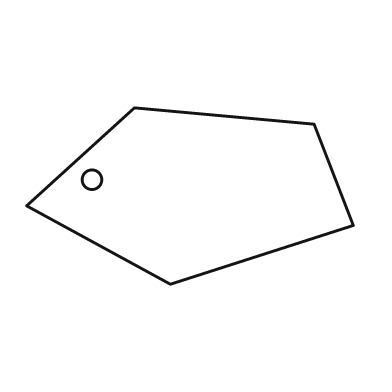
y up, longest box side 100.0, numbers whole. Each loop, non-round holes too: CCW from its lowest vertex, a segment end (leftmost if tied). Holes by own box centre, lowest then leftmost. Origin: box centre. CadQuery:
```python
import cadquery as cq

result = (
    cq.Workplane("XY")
    .moveTo(-6.0, -27.0)
    .lineTo(50.0, -9.0)
    .lineTo(38.0, 22.0)
    .lineTo(-17.0, 27.0)
    .lineTo(-50.0, -3.0)
    .close()
    .moveTo(-30.0, 5.0)
    .circle(3.0)
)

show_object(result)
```